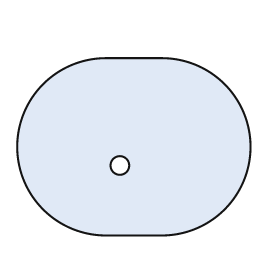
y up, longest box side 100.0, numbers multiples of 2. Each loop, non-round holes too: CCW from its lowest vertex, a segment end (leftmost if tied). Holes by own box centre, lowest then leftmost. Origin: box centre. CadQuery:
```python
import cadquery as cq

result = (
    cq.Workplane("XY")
    .moveTo(-12.0, -38.0)
    .lineTo(12.0, -38.0)
    .threePointArc((50.0, 0.0), (12.0, 38.0))
    .lineTo(-12.0, 38.0)
    .threePointArc((-50.0, 0.0), (-12.0, -38.0))
    .close()
    .moveTo(-6.0, -8.0)
    .circle(4.0)
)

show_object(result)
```